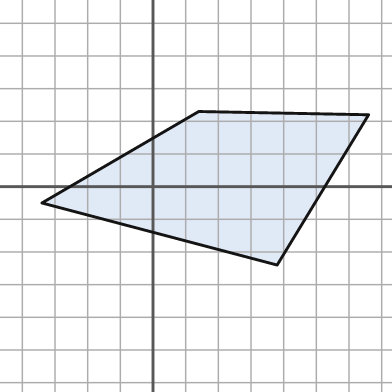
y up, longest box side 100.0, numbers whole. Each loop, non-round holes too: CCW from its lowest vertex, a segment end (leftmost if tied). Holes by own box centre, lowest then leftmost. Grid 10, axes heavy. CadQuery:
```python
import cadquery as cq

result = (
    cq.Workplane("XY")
    .moveTo(38.0, -24.0)
    .lineTo(66.0, 22.0)
    .lineTo(14.0, 23.0)
    .lineTo(-34.0, -5.0)
    .close()
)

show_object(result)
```